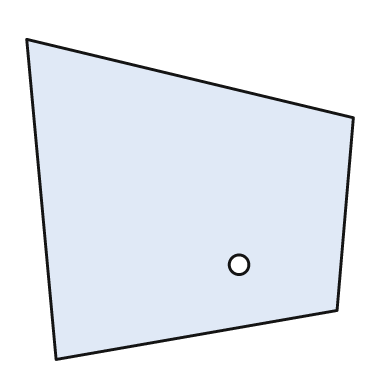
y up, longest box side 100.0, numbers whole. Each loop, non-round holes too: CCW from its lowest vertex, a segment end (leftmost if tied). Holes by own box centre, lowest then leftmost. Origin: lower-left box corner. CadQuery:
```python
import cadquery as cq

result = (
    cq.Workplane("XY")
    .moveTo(9.0, 0.0)
    .lineTo(95.0, 15.0)
    .lineTo(100.0, 74.0)
    .lineTo(0.0, 98.0)
    .close()
    .moveTo(65.0, 29.0)
    .circle(3.0)
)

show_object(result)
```